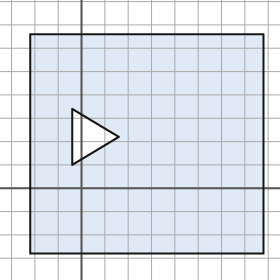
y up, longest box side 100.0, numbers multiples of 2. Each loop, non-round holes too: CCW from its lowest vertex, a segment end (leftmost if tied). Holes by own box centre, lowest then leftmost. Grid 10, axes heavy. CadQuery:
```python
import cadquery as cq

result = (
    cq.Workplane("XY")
    .moveTo(-22.0, -28.0)
    .lineTo(78.0, -28.0)
    .lineTo(78.0, 66.0)
    .lineTo(-22.0, 66.0)
    .close()
    .moveTo(-4.0, 10.0)
    .lineTo(16.0, 22.0)
    .lineTo(-4.0, 34.0)
    .close()
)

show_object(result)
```